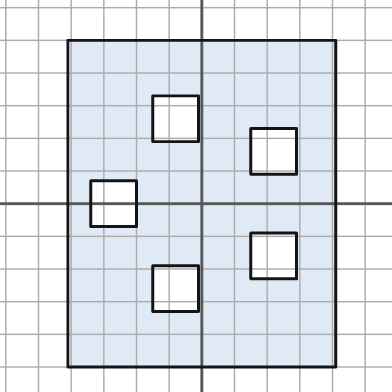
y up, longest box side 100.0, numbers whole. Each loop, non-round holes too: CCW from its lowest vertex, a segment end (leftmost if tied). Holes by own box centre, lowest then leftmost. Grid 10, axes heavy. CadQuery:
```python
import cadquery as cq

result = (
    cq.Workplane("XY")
    .moveTo(-41.0, -50.0)
    .lineTo(41.0, -50.0)
    .lineTo(41.0, 50.0)
    .lineTo(-41.0, 50.0)
    .close()
    .moveTo(-15.0, -33.0)
    .lineTo(-1.0, -33.0)
    .lineTo(-1.0, -19.0)
    .lineTo(-15.0, -19.0)
    .close()
    .moveTo(15.0, -23.0)
    .lineTo(29.0, -23.0)
    .lineTo(29.0, -9.0)
    .lineTo(15.0, -9.0)
    .close()
    .moveTo(-34.0, -7.0)
    .lineTo(-20.0, -7.0)
    .lineTo(-20.0, 7.0)
    .lineTo(-34.0, 7.0)
    .close()
    .moveTo(15.0, 9.0)
    .lineTo(29.0, 9.0)
    .lineTo(29.0, 23.0)
    .lineTo(15.0, 23.0)
    .close()
    .moveTo(-15.0, 19.0)
    .lineTo(-1.0, 19.0)
    .lineTo(-1.0, 33.0)
    .lineTo(-15.0, 33.0)
    .close()
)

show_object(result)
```